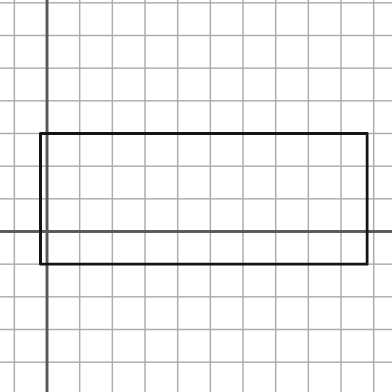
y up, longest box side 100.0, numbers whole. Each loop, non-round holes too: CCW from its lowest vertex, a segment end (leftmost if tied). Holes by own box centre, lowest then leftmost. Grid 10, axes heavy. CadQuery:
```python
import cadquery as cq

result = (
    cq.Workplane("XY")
    .moveTo(-2.0, -10.0)
    .lineTo(98.0, -10.0)
    .lineTo(98.0, 30.0)
    .lineTo(-2.0, 30.0)
    .close()
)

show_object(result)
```